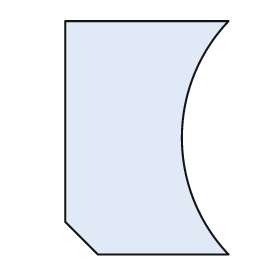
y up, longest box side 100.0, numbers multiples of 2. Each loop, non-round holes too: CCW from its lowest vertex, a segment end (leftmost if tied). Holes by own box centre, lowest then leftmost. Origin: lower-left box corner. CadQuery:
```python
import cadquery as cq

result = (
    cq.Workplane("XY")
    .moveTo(14.0, 0.0)
    .lineTo(70.0, 0.0)
    .threePointArc((50.0, 50.0), (70.0, 100.0))
    .lineTo(0.0, 100.0)
    .lineTo(0.0, 14.0)
    .close()
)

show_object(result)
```